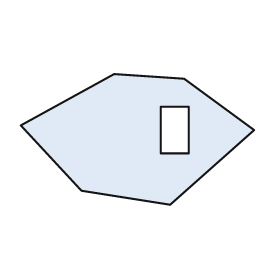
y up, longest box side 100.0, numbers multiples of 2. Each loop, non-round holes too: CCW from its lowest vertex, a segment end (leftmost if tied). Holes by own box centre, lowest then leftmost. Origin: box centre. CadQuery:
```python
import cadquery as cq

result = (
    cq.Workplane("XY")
    .moveTo(14.0, -28.0)
    .lineTo(50.0, 4.0)
    .lineTo(20.0, 26.0)
    .lineTo(-10.0, 28.0)
    .lineTo(-50.0, 6.0)
    .lineTo(-24.0, -22.0)
    .close()
    .moveTo(10.0, -6.0)
    .lineTo(22.0, -6.0)
    .lineTo(22.0, 14.0)
    .lineTo(10.0, 14.0)
    .close()
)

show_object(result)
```